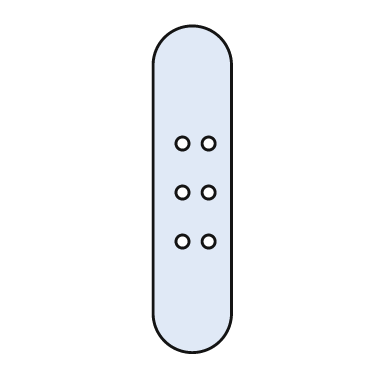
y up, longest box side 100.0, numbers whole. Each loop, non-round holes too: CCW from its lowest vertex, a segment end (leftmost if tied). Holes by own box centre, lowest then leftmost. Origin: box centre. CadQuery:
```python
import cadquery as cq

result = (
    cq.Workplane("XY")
    .moveTo(-12.0, -38.0)
    .threePointArc((0.0, -50.0), (12.0, -38.0))
    .lineTo(12.0, 38.0)
    .threePointArc((0.0, 50.0), (-12.0, 38.0))
    .close()
    .moveTo(-3.0, -16.0)
    .circle(2.0)
    .moveTo(5.0, -16.0)
    .circle(2.0)
    .moveTo(-3.0, -1.0)
    .circle(2.0)
    .moveTo(5.0, -1.0)
    .circle(2.0)
    .moveTo(-3.0, 14.0)
    .circle(2.0)
    .moveTo(5.0, 14.0)
    .circle(2.0)
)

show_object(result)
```